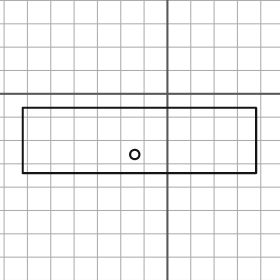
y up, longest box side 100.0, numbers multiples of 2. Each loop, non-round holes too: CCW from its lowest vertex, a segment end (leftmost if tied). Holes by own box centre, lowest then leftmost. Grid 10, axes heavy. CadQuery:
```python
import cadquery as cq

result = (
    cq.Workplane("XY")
    .moveTo(-62.0, -34.0)
    .lineTo(38.0, -34.0)
    .lineTo(38.0, -6.0)
    .lineTo(-62.0, -6.0)
    .close()
    .moveTo(-14.0, -26.0)
    .circle(2.0)
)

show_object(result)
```